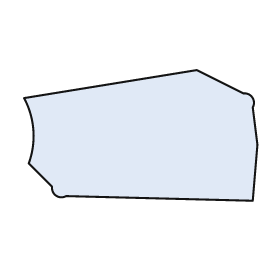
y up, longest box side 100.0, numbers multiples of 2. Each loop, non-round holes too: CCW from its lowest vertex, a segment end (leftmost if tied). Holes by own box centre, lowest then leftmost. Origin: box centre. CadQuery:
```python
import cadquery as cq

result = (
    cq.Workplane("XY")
    .moveTo(48.0, -28.0)
    .lineTo(50.0, -4.0)
    .lineTo(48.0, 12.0)
    .threePointArc((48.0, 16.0), (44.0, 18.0))
    .lineTo(24.0, 28.0)
    .lineTo(-50.0, 16.0)
    .threePointArc((-46.0, 2.0), (-48.0, -12.0))
    .lineTo(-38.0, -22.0)
    .threePointArc((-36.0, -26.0), (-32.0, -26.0))
    .close()
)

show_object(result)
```